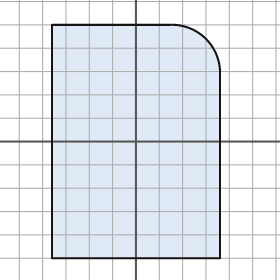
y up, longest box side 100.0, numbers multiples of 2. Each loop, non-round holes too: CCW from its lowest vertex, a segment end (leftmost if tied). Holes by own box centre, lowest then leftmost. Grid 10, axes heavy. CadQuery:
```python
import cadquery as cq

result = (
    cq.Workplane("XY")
    .moveTo(-36.0, -50.0)
    .lineTo(36.0, -50.0)
    .lineTo(36.0, 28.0)
    .threePointArc((30.0, 44.0), (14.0, 50.0))
    .lineTo(-36.0, 50.0)
    .close()
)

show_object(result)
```